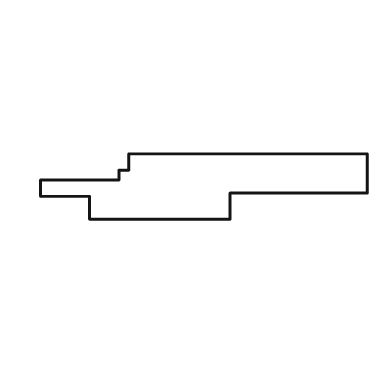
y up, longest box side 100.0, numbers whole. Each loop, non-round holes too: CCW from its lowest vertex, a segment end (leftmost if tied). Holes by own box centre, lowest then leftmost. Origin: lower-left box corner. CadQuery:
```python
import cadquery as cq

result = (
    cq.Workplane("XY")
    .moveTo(15.0, 0.0)
    .lineTo(58.0, 0.0)
    .lineTo(58.0, 8.0)
    .lineTo(100.0, 8.0)
    .lineTo(100.0, 20.0)
    .lineTo(27.0, 20.0)
    .lineTo(27.0, 15.0)
    .lineTo(24.0, 15.0)
    .lineTo(24.0, 12.0)
    .lineTo(0.0, 12.0)
    .lineTo(0.0, 7.0)
    .lineTo(15.0, 7.0)
    .close()
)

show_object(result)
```